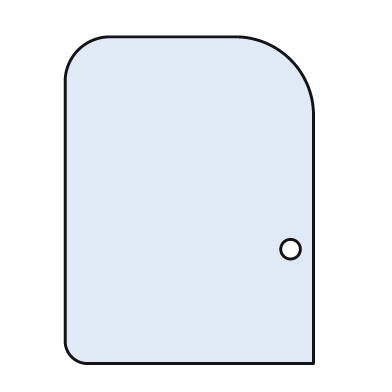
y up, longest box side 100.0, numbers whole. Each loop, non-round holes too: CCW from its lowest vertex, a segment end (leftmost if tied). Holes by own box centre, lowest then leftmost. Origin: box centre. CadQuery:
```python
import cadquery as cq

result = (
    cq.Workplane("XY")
    .moveTo(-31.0, -50.0)
    .lineTo(38.0, -50.0)
    .lineTo(38.0, 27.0)
    .threePointArc((31.0, 43.0), (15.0, 50.0))
    .lineTo(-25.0, 50.0)
    .threePointArc((-34.0, 46.0), (-38.0, 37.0))
    .lineTo(-38.0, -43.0)
    .threePointArc((-36.0, -48.0), (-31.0, -50.0))
    .close()
    .moveTo(31.0, -15.0)
    .circle(3.0)
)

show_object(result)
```